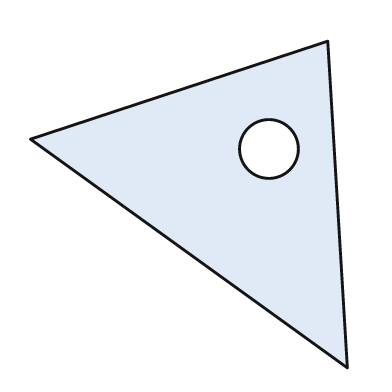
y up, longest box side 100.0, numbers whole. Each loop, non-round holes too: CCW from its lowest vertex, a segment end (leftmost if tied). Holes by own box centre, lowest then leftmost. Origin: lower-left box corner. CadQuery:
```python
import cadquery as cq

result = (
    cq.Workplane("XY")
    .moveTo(97.0, 0.0)
    .lineTo(91.0, 100.0)
    .lineTo(0.0, 70.0)
    .close()
    .moveTo(73.0, 67.0)
    .circle(9.0)
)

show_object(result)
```